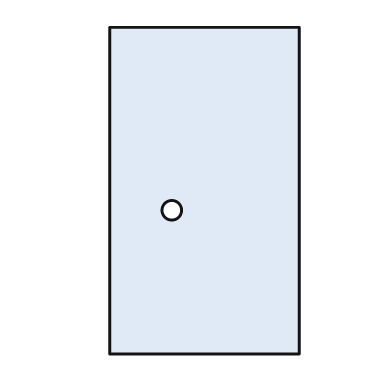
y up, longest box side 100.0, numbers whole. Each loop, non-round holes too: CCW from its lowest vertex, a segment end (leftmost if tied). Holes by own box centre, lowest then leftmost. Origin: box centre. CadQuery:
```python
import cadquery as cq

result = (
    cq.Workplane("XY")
    .moveTo(-29.0, -50.0)
    .lineTo(29.0, -50.0)
    .lineTo(29.0, 50.0)
    .lineTo(-29.0, 50.0)
    .close()
    .moveTo(-10.0, -6.0)
    .circle(3.0)
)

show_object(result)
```